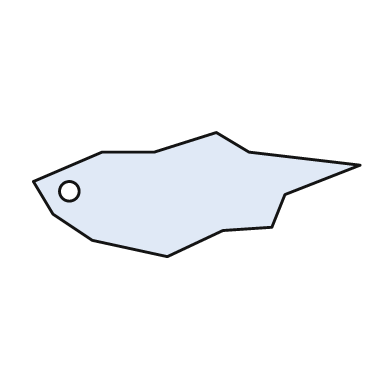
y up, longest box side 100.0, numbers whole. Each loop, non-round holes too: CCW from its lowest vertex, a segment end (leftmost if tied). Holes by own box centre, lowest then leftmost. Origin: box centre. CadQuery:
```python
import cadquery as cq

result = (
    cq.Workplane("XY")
    .moveTo(-9.0, -19.0)
    .lineTo(8.0, -11.0)
    .lineTo(23.0, -10.0)
    .lineTo(27.0, 0.0)
    .lineTo(50.0, 9.0)
    .lineTo(16.0, 13.0)
    .lineTo(6.0, 19.0)
    .lineTo(-13.0, 13.0)
    .lineTo(-29.0, 13.0)
    .lineTo(-50.0, 4.0)
    .lineTo(-44.0, -6.0)
    .lineTo(-32.0, -14.0)
    .close()
    .moveTo(-39.0, 1.0)
    .circle(3.0)
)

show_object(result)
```